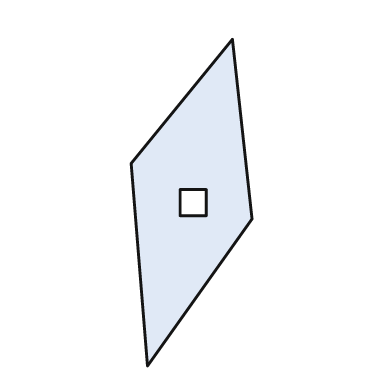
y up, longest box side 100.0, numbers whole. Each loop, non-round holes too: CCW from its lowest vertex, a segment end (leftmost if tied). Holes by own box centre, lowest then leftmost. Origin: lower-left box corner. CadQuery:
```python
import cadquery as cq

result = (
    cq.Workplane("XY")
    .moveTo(5.0, 0.0)
    .lineTo(37.0, 45.0)
    .lineTo(31.0, 100.0)
    .lineTo(0.0, 62.0)
    .close()
    .moveTo(15.0, 46.0)
    .lineTo(23.0, 46.0)
    .lineTo(23.0, 54.0)
    .lineTo(15.0, 54.0)
    .close()
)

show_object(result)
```